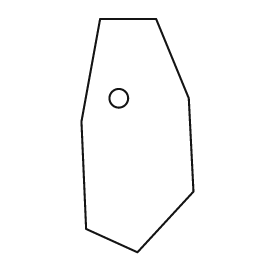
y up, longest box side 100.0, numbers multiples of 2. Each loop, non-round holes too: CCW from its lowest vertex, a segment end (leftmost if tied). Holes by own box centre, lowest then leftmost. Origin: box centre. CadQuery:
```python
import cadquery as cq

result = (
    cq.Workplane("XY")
    .moveTo(0.0, -50.0)
    .lineTo(24.0, -24.0)
    .lineTo(22.0, 16.0)
    .lineTo(8.0, 50.0)
    .lineTo(-16.0, 50.0)
    .lineTo(-24.0, 6.0)
    .lineTo(-22.0, -40.0)
    .close()
    .moveTo(-8.0, 16.0)
    .circle(4.0)
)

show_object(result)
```